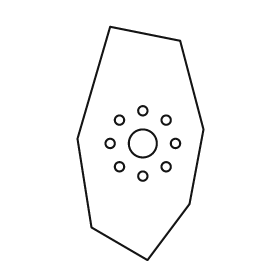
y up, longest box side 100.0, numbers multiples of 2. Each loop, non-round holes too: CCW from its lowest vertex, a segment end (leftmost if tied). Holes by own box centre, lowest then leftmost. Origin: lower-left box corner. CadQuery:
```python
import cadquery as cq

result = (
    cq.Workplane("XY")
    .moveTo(30.0, 0.0)
    .lineTo(48.0, 24.0)
    .lineTo(54.0, 56.0)
    .lineTo(44.0, 94.0)
    .lineTo(14.0, 100.0)
    .lineTo(0.0, 52.0)
    .lineTo(6.0, 14.0)
    .close()
    .moveTo(28.0, 36.0)
    .circle(2.0)
    .moveTo(18.0, 40.0)
    .circle(2.0)
    .moveTo(38.0, 40.0)
    .circle(2.0)
    .moveTo(14.0, 50.0)
    .circle(2.0)
    .moveTo(28.0, 50.0)
    .circle(6.0)
    .moveTo(42.0, 50.0)
    .circle(2.0)
    .moveTo(18.0, 60.0)
    .circle(2.0)
    .moveTo(38.0, 60.0)
    .circle(2.0)
    .moveTo(28.0, 64.0)
    .circle(2.0)
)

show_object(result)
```